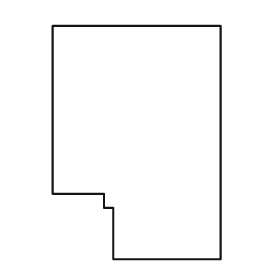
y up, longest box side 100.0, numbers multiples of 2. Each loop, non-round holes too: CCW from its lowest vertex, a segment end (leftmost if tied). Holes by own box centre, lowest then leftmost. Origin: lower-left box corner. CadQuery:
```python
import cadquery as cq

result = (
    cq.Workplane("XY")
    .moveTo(26.0, 0.0)
    .lineTo(72.0, 0.0)
    .lineTo(72.0, 100.0)
    .lineTo(0.0, 100.0)
    .lineTo(0.0, 28.0)
    .lineTo(22.0, 28.0)
    .lineTo(22.0, 22.0)
    .lineTo(26.0, 22.0)
    .close()
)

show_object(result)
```